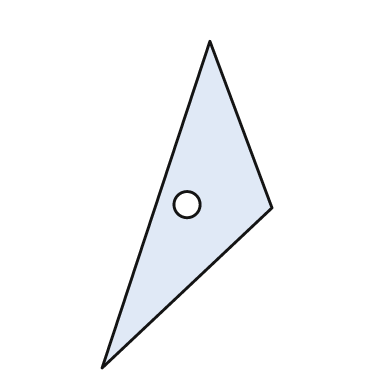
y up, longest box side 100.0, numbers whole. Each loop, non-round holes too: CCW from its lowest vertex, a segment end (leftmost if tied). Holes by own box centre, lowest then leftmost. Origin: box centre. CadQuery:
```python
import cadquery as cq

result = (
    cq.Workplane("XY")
    .moveTo(-26.0, -50.0)
    .lineTo(26.0, -1.0)
    .lineTo(7.0, 50.0)
    .close()
    .moveTo(0.0, 0.0)
    .circle(4.0)
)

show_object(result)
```